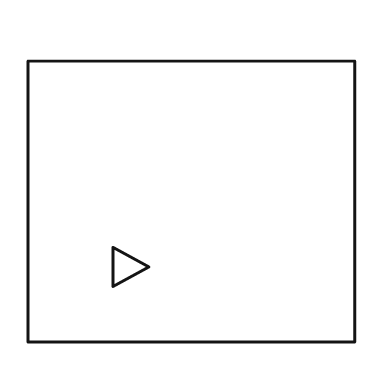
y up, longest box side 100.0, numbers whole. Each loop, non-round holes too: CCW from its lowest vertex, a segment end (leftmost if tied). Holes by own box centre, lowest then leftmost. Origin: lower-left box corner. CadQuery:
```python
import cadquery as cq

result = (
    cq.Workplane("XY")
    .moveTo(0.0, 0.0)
    .lineTo(100.0, 0.0)
    .lineTo(100.0, 86.0)
    .lineTo(0.0, 86.0)
    .close()
    .moveTo(26.0, 17.0)
    .lineTo(37.0, 23.0)
    .lineTo(26.0, 29.0)
    .close()
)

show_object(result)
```